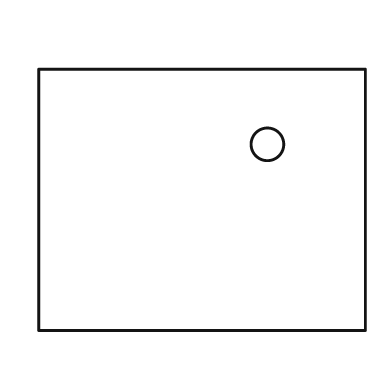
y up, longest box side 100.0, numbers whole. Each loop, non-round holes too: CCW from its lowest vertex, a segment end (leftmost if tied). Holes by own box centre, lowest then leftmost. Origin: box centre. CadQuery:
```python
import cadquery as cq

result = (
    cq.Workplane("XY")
    .moveTo(-50.0, -40.0)
    .lineTo(50.0, -40.0)
    .lineTo(50.0, 40.0)
    .lineTo(-50.0, 40.0)
    .close()
    .moveTo(20.0, 17.0)
    .circle(5.0)
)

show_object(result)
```